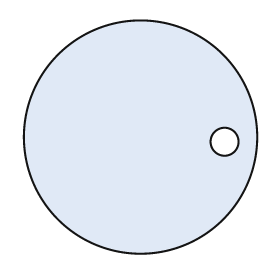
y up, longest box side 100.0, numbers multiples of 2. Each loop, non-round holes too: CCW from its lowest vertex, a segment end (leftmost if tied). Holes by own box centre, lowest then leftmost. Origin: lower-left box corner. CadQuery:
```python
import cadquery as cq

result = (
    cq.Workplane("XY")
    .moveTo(50.0, 50.0)
    .circle(50.0)
    .moveTo(86.0, 48.0)
    .circle(6.0)
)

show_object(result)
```